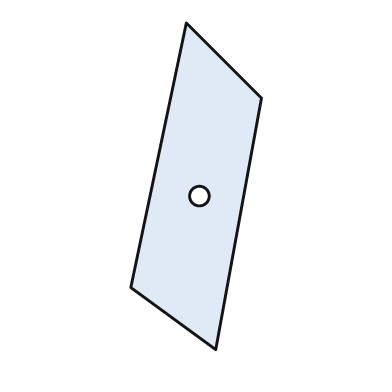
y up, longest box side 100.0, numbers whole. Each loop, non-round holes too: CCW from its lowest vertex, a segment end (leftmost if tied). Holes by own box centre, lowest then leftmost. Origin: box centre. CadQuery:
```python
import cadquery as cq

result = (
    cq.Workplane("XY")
    .moveTo(6.0, -50.0)
    .lineTo(20.0, 27.0)
    .lineTo(-3.0, 50.0)
    .lineTo(-20.0, -31.0)
    .close()
    .moveTo(1.0, -3.0)
    .circle(3.0)
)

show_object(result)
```